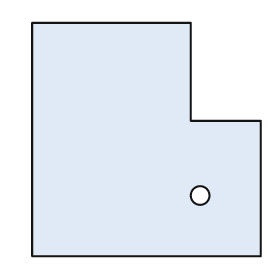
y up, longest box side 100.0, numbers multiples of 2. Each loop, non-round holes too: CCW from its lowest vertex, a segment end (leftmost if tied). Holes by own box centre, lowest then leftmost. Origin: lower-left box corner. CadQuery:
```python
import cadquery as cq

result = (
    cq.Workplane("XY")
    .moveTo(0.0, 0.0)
    .lineTo(98.0, 0.0)
    .lineTo(98.0, 58.0)
    .lineTo(68.0, 58.0)
    .lineTo(68.0, 100.0)
    .lineTo(0.0, 100.0)
    .close()
    .moveTo(72.0, 26.0)
    .circle(4.0)
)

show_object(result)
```